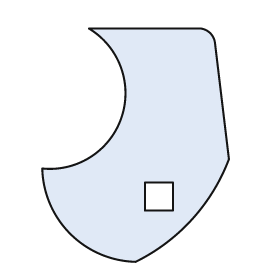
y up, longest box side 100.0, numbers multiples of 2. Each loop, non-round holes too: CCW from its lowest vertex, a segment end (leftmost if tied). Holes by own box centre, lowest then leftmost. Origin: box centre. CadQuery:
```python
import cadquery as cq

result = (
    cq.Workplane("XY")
    .moveTo(0.0, -50.0)
    .threePointArc((24.0, -32.0), (40.0, -6.0))
    .lineTo(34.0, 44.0)
    .threePointArc((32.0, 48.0), (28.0, 50.0))
    .lineTo(-20.0, 50.0)
    .threePointArc((-6.0, 12.0), (-40.0, -10.0))
    .threePointArc((-28.0, -38.0), (0.0, -50.0))
    .close()
    .moveTo(4.0, -28.0)
    .lineTo(16.0, -28.0)
    .lineTo(16.0, -16.0)
    .lineTo(4.0, -16.0)
    .close()
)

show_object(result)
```